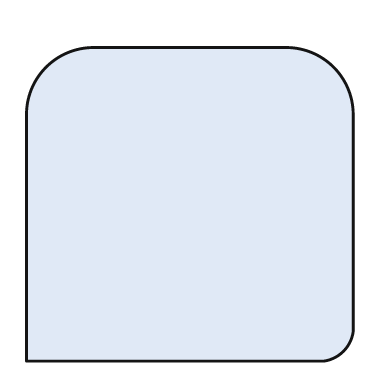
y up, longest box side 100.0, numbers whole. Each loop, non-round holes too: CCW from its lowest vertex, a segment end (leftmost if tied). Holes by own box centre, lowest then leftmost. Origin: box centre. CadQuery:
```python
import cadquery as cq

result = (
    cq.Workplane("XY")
    .moveTo(-50.0, -48.0)
    .lineTo(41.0, -48.0)
    .threePointArc((47.0, -45.0), (50.0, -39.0))
    .lineTo(50.0, 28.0)
    .threePointArc((44.0, 42.0), (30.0, 48.0))
    .lineTo(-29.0, 48.0)
    .threePointArc((-44.0, 42.0), (-50.0, 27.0))
    .close()
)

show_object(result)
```